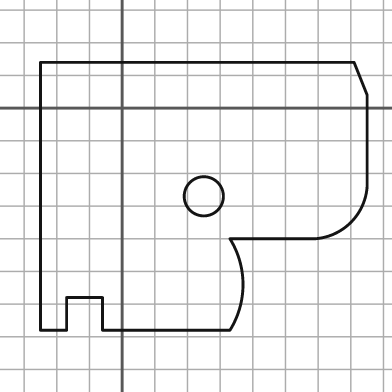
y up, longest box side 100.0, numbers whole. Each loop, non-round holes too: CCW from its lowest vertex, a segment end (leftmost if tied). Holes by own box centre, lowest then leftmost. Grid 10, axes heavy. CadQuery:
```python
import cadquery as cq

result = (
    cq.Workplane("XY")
    .moveTo(-25.0, -68.0)
    .lineTo(-17.0, -68.0)
    .lineTo(-17.0, -58.0)
    .lineTo(-6.0, -58.0)
    .lineTo(-6.0, -68.0)
    .lineTo(33.0, -68.0)
    .threePointArc((37.0, -54.0), (33.0, -40.0))
    .lineTo(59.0, -40.0)
    .threePointArc((70.0, -35.0), (75.0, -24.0))
    .lineTo(75.0, 4.0)
    .lineTo(71.0, 14.0)
    .lineTo(-25.0, 14.0)
    .close()
    .moveTo(25.0, -27.0)
    .circle(6.0)
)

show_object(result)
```